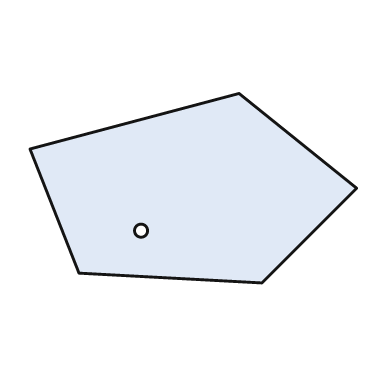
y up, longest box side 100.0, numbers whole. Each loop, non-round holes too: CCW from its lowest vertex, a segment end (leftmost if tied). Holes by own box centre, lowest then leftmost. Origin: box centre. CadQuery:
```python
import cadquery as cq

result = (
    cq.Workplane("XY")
    .moveTo(21.0, -29.0)
    .lineTo(50.0, 0.0)
    .lineTo(14.0, 29.0)
    .lineTo(-50.0, 12.0)
    .lineTo(-35.0, -26.0)
    .close()
    .moveTo(-16.0, -13.0)
    .circle(2.0)
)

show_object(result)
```